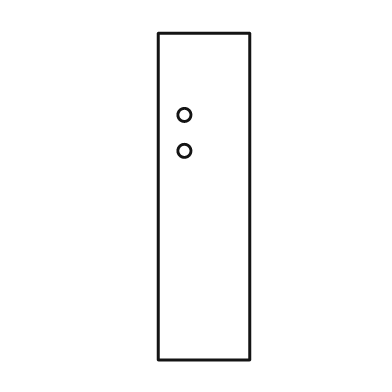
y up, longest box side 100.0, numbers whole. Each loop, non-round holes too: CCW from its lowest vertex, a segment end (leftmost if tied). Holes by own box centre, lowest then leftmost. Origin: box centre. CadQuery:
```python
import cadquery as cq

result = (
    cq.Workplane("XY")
    .moveTo(-14.0, -50.0)
    .lineTo(14.0, -50.0)
    .lineTo(14.0, 50.0)
    .lineTo(-14.0, 50.0)
    .close()
    .moveTo(-6.0, 14.0)
    .circle(2.0)
    .moveTo(-6.0, 25.0)
    .circle(2.0)
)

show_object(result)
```